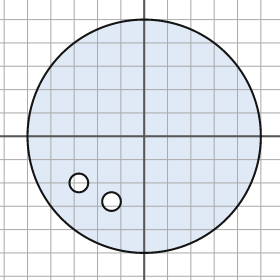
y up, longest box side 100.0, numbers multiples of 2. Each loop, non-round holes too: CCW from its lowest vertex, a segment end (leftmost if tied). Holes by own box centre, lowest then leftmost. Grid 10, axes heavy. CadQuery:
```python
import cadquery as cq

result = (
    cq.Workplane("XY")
    .moveTo(0.0, 0.0)
    .circle(50.0)
    .moveTo(-14.0, -28.0)
    .circle(4.0)
    .moveTo(-28.0, -20.0)
    .circle(4.0)
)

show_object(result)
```